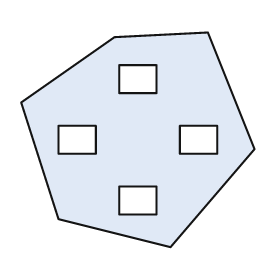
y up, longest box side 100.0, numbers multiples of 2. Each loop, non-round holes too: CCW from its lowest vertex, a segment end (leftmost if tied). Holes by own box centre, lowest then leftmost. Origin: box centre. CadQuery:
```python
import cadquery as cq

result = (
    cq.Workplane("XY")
    .moveTo(14.0, -46.0)
    .lineTo(50.0, -4.0)
    .lineTo(30.0, 46.0)
    .lineTo(-10.0, 44.0)
    .lineTo(-50.0, 16.0)
    .lineTo(-34.0, -34.0)
    .close()
    .moveTo(-8.0, -32.0)
    .lineTo(8.0, -32.0)
    .lineTo(8.0, -20.0)
    .lineTo(-8.0, -20.0)
    .close()
    .moveTo(-34.0, -6.0)
    .lineTo(-18.0, -6.0)
    .lineTo(-18.0, 6.0)
    .lineTo(-34.0, 6.0)
    .close()
    .moveTo(18.0, -6.0)
    .lineTo(34.0, -6.0)
    .lineTo(34.0, 6.0)
    .lineTo(18.0, 6.0)
    .close()
    .moveTo(-8.0, 20.0)
    .lineTo(8.0, 20.0)
    .lineTo(8.0, 32.0)
    .lineTo(-8.0, 32.0)
    .close()
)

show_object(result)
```